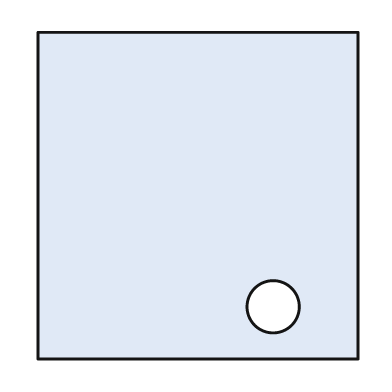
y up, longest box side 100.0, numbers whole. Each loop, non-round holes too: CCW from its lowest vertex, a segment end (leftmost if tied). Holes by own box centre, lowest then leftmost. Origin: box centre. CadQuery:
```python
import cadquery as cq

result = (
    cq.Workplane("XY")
    .moveTo(-49.0, -50.0)
    .lineTo(49.0, -50.0)
    .lineTo(49.0, 50.0)
    .lineTo(-49.0, 50.0)
    .close()
    .moveTo(23.0, -34.0)
    .circle(8.0)
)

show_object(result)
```